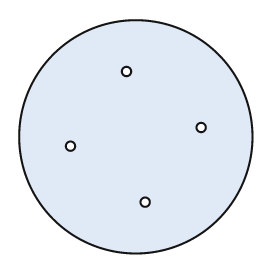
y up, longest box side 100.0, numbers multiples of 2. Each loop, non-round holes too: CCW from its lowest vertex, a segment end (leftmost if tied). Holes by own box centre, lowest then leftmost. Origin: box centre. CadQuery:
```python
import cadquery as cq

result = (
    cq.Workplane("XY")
    .moveTo(0.0, 0.0)
    .circle(50.0)
    .moveTo(4.0, -28.0)
    .circle(2.0)
    .moveTo(-28.0, -4.0)
    .circle(2.0)
    .moveTo(28.0, 4.0)
    .circle(2.0)
    .moveTo(-4.0, 28.0)
    .circle(2.0)
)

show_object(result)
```